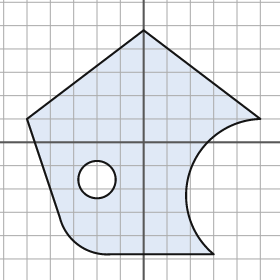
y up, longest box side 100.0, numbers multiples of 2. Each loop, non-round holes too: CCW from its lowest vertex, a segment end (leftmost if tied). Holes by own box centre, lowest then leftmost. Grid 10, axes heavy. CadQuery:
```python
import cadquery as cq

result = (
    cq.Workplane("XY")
    .moveTo(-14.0, -48.0)
    .lineTo(30.0, -48.0)
    .threePointArc((20.0, -12.0), (50.0, 10.0))
    .lineTo(0.0, 48.0)
    .lineTo(-50.0, 10.0)
    .lineTo(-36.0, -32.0)
    .threePointArc((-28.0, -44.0), (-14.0, -48.0))
    .close()
    .moveTo(-20.0, -16.0)
    .circle(8.0)
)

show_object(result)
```